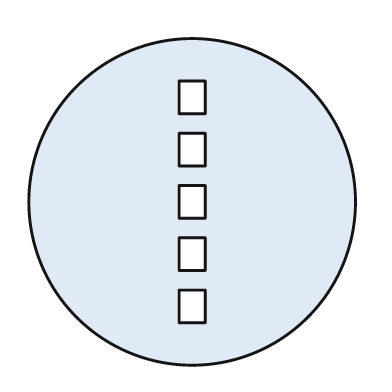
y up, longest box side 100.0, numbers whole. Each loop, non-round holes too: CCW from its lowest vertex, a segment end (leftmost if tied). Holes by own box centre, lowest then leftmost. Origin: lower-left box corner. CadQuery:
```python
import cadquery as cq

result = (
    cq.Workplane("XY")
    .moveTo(50.0, 50.0)
    .circle(50.0)
    .moveTo(46.0, 13.0)
    .lineTo(54.0, 13.0)
    .lineTo(54.0, 23.0)
    .lineTo(46.0, 23.0)
    .close()
    .moveTo(46.0, 29.0)
    .lineTo(54.0, 29.0)
    .lineTo(54.0, 39.0)
    .lineTo(46.0, 39.0)
    .close()
    .moveTo(46.0, 45.0)
    .lineTo(54.0, 45.0)
    .lineTo(54.0, 55.0)
    .lineTo(46.0, 55.0)
    .close()
    .moveTo(46.0, 61.0)
    .lineTo(54.0, 61.0)
    .lineTo(54.0, 71.0)
    .lineTo(46.0, 71.0)
    .close()
    .moveTo(46.0, 77.0)
    .lineTo(54.0, 77.0)
    .lineTo(54.0, 87.0)
    .lineTo(46.0, 87.0)
    .close()
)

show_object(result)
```